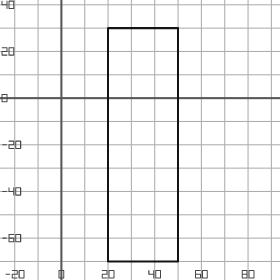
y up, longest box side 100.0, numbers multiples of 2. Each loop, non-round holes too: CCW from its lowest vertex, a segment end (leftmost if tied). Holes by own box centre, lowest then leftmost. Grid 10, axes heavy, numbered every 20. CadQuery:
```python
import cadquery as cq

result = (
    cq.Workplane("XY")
    .moveTo(20.0, -70.0)
    .lineTo(50.0, -70.0)
    .lineTo(50.0, 30.0)
    .lineTo(20.0, 30.0)
    .close()
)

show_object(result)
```